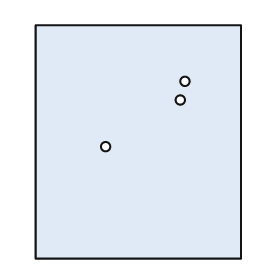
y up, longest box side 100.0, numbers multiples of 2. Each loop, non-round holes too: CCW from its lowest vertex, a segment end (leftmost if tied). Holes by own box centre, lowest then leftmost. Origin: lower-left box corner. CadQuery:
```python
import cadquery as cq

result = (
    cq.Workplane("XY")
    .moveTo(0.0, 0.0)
    .lineTo(88.0, 0.0)
    .lineTo(88.0, 100.0)
    .lineTo(0.0, 100.0)
    .close()
    .moveTo(30.0, 48.0)
    .circle(2.0)
    .moveTo(62.0, 68.0)
    .circle(2.0)
    .moveTo(64.0, 76.0)
    .circle(2.0)
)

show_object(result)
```